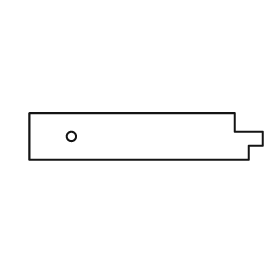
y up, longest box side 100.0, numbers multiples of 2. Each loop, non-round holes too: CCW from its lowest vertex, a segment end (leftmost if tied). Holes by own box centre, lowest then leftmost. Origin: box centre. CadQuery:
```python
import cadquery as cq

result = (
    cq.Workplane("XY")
    .moveTo(-50.0, -10.0)
    .lineTo(44.0, -10.0)
    .lineTo(44.0, -4.0)
    .lineTo(50.0, -4.0)
    .lineTo(50.0, 2.0)
    .lineTo(38.0, 2.0)
    .lineTo(38.0, 10.0)
    .lineTo(-50.0, 10.0)
    .close()
    .moveTo(-32.0, 0.0)
    .circle(2.0)
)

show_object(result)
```